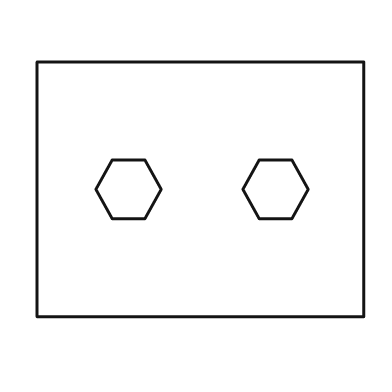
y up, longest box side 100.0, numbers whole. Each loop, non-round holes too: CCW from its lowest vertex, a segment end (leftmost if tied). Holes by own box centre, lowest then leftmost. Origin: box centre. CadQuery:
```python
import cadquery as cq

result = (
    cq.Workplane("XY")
    .moveTo(-50.0, -39.0)
    .lineTo(50.0, -39.0)
    .lineTo(50.0, 39.0)
    .lineTo(-50.0, 39.0)
    .close()
    .moveTo(-27.0, -9.0)
    .lineTo(-17.0, -9.0)
    .lineTo(-12.0, 0.0)
    .lineTo(-17.0, 9.0)
    .lineTo(-27.0, 9.0)
    .lineTo(-32.0, 0.0)
    .close()
    .moveTo(18.0, -9.0)
    .lineTo(28.0, -9.0)
    .lineTo(33.0, 0.0)
    .lineTo(28.0, 9.0)
    .lineTo(18.0, 9.0)
    .lineTo(13.0, 0.0)
    .close()
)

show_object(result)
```